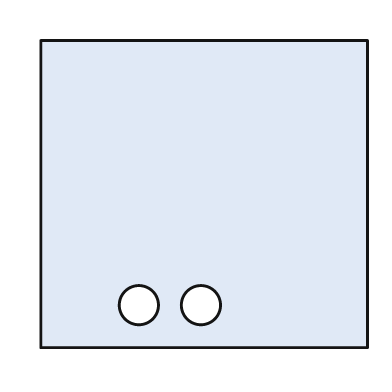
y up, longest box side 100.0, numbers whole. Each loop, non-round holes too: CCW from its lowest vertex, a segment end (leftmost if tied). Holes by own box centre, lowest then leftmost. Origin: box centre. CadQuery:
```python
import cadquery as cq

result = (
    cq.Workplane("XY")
    .moveTo(-50.0, -47.0)
    .lineTo(50.0, -47.0)
    .lineTo(50.0, 47.0)
    .lineTo(-50.0, 47.0)
    .close()
    .moveTo(-20.0, -34.0)
    .circle(6.0)
    .moveTo(-1.0, -34.0)
    .circle(6.0)
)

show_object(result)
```